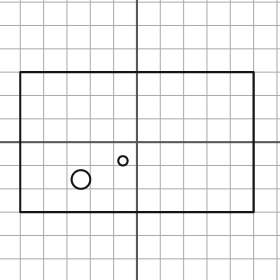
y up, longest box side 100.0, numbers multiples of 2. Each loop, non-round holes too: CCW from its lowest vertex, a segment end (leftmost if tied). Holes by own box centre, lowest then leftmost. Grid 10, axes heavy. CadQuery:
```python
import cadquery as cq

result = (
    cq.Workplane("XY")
    .moveTo(-50.0, -30.0)
    .lineTo(50.0, -30.0)
    .lineTo(50.0, 30.0)
    .lineTo(-50.0, 30.0)
    .close()
    .moveTo(-24.0, -16.0)
    .circle(4.0)
    .moveTo(-6.0, -8.0)
    .circle(2.0)
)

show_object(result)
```